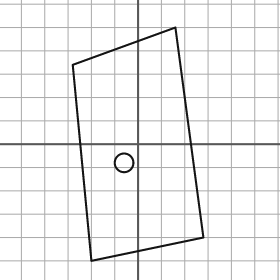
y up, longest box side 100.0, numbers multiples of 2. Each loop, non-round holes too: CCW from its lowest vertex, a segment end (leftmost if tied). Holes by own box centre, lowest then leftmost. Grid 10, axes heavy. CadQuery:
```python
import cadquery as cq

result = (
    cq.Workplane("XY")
    .moveTo(-20.0, -50.0)
    .lineTo(28.0, -40.0)
    .lineTo(16.0, 50.0)
    .lineTo(-28.0, 34.0)
    .close()
    .moveTo(-6.0, -8.0)
    .circle(4.0)
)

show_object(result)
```